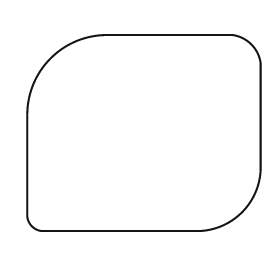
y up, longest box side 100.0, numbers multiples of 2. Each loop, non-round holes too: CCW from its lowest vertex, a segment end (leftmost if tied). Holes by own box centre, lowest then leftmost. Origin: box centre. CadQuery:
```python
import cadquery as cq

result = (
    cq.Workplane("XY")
    .moveTo(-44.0, -42.0)
    .lineTo(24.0, -42.0)
    .threePointArc((42.0, -34.0), (50.0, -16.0))
    .lineTo(50.0, 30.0)
    .threePointArc((46.0, 38.0), (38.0, 42.0))
    .lineTo(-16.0, 42.0)
    .threePointArc((-40.0, 32.0), (-50.0, 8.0))
    .lineTo(-50.0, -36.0)
    .threePointArc((-48.0, -40.0), (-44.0, -42.0))
    .close()
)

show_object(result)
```